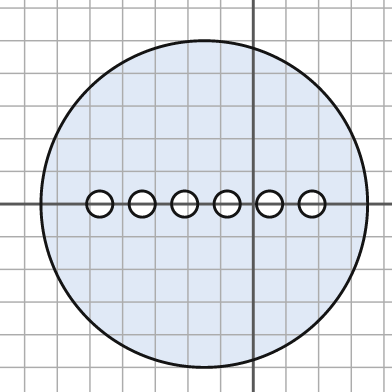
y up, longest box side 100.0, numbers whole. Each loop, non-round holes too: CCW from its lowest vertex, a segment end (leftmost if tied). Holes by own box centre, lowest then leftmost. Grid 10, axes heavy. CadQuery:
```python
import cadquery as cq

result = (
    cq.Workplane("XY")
    .moveTo(-15.0, 0.0)
    .circle(50.0)
    .moveTo(-47.0, 0.0)
    .circle(4.0)
    .moveTo(-34.0, 0.0)
    .circle(4.0)
    .moveTo(-21.0, 0.0)
    .circle(4.0)
    .moveTo(-8.0, 0.0)
    .circle(4.0)
    .moveTo(5.0, 0.0)
    .circle(4.0)
    .moveTo(18.0, 0.0)
    .circle(4.0)
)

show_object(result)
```